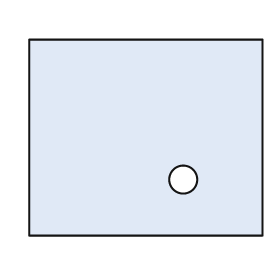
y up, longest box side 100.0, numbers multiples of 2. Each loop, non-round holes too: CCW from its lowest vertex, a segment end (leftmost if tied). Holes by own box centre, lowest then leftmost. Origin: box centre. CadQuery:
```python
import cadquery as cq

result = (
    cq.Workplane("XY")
    .moveTo(-50.0, -42.0)
    .lineTo(50.0, -42.0)
    .lineTo(50.0, 42.0)
    .lineTo(-50.0, 42.0)
    .close()
    .moveTo(16.0, -18.0)
    .circle(6.0)
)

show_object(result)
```